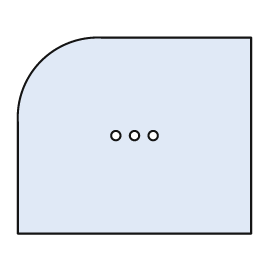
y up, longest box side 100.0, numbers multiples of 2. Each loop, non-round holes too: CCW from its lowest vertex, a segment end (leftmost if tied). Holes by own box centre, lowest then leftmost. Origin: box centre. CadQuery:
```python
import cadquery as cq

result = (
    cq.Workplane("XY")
    .moveTo(-50.0, -42.0)
    .lineTo(50.0, -42.0)
    .lineTo(50.0, 42.0)
    .lineTo(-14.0, 42.0)
    .threePointArc((-40.0, 32.0), (-50.0, 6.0))
    .close()
    .moveTo(-8.0, 0.0)
    .circle(2.0)
    .moveTo(0.0, 0.0)
    .circle(2.0)
    .moveTo(8.0, 0.0)
    .circle(2.0)
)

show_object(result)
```